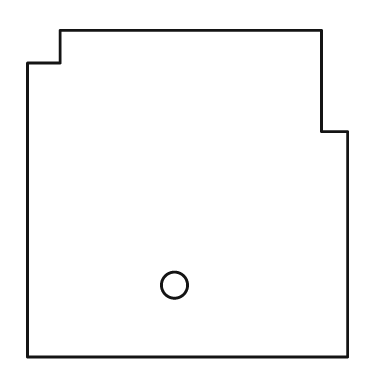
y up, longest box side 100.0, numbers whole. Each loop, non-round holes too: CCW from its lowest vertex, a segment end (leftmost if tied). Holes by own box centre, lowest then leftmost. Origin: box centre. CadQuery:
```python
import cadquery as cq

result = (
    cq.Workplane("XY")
    .moveTo(-49.0, -50.0)
    .lineTo(49.0, -50.0)
    .lineTo(49.0, 19.0)
    .lineTo(41.0, 19.0)
    .lineTo(41.0, 50.0)
    .lineTo(-39.0, 50.0)
    .lineTo(-39.0, 40.0)
    .lineTo(-49.0, 40.0)
    .close()
    .moveTo(-4.0, -28.0)
    .circle(4.0)
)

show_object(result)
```